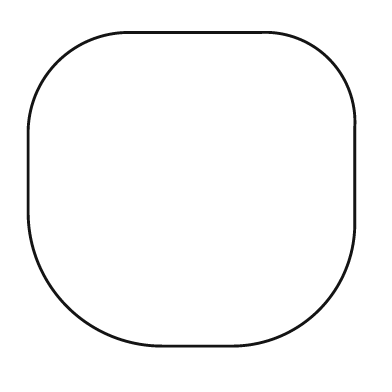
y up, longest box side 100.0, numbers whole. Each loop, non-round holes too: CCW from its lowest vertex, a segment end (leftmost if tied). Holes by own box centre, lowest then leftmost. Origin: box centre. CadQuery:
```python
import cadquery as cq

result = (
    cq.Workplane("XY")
    .moveTo(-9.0, -48.0)
    .lineTo(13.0, -48.0)
    .threePointArc((39.0, -37.0), (50.0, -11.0))
    .lineTo(50.0, 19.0)
    .threePointArc((42.0, 40.0), (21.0, 48.0))
    .lineTo(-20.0, 48.0)
    .threePointArc((-41.0, 39.0), (-50.0, 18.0))
    .lineTo(-50.0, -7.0)
    .threePointArc((-38.0, -36.0), (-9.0, -48.0))
    .close()
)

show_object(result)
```